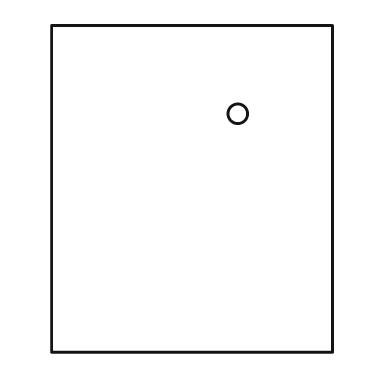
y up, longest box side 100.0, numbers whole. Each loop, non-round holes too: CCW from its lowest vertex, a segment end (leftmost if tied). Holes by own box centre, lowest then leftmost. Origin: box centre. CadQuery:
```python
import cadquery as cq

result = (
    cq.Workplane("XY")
    .moveTo(-43.0, -50.0)
    .lineTo(43.0, -50.0)
    .lineTo(43.0, 50.0)
    .lineTo(-43.0, 50.0)
    .close()
    .moveTo(14.0, 23.0)
    .circle(3.0)
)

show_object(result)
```